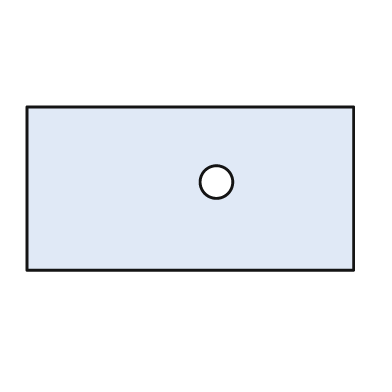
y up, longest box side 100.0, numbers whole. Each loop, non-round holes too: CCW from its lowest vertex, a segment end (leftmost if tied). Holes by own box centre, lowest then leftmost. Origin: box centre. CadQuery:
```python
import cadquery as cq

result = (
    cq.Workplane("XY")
    .moveTo(-50.0, -25.0)
    .lineTo(50.0, -25.0)
    .lineTo(50.0, 25.0)
    .lineTo(-50.0, 25.0)
    .close()
    .moveTo(8.0, 2.0)
    .circle(5.0)
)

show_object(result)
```